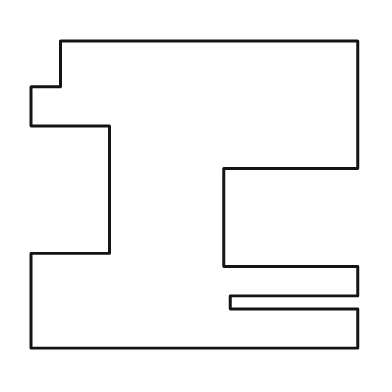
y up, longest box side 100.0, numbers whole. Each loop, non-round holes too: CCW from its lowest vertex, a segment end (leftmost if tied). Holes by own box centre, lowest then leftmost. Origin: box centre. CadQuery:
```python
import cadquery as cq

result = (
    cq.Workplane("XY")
    .moveTo(-50.0, -47.0)
    .lineTo(50.0, -47.0)
    .lineTo(50.0, -35.0)
    .lineTo(11.0, -35.0)
    .lineTo(11.0, -31.0)
    .lineTo(50.0, -31.0)
    .lineTo(50.0, -22.0)
    .lineTo(9.0, -22.0)
    .lineTo(9.0, 8.0)
    .lineTo(50.0, 8.0)
    .lineTo(50.0, 47.0)
    .lineTo(-41.0, 47.0)
    .lineTo(-41.0, 33.0)
    .lineTo(-50.0, 33.0)
    .lineTo(-50.0, 21.0)
    .lineTo(-26.0, 21.0)
    .lineTo(-26.0, -18.0)
    .lineTo(-50.0, -18.0)
    .close()
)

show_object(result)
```